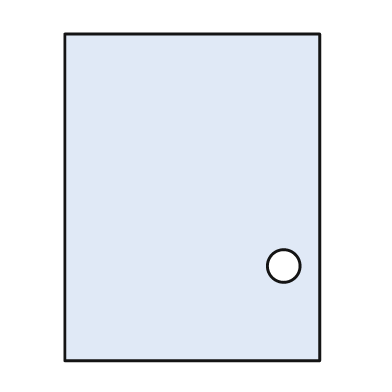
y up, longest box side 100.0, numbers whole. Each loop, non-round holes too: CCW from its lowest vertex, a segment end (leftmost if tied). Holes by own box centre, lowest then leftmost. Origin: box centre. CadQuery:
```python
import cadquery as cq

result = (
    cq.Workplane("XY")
    .moveTo(-39.0, -50.0)
    .lineTo(39.0, -50.0)
    .lineTo(39.0, 50.0)
    .lineTo(-39.0, 50.0)
    .close()
    .moveTo(28.0, -21.0)
    .circle(5.0)
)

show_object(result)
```